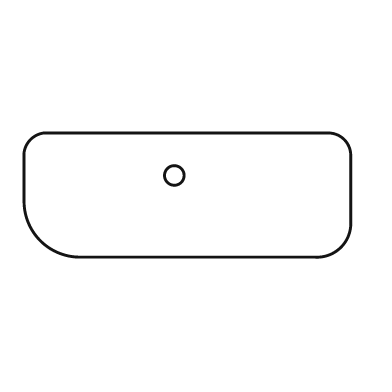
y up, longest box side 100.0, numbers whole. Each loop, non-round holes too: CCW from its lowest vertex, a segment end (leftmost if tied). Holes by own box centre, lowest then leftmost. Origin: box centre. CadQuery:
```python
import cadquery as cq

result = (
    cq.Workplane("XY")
    .moveTo(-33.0, -19.0)
    .lineTo(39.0, -19.0)
    .threePointArc((47.0, -16.0), (50.0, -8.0))
    .lineTo(50.0, 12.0)
    .threePointArc((48.0, 17.0), (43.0, 19.0))
    .lineTo(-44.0, 19.0)
    .threePointArc((-48.0, 17.0), (-50.0, 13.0))
    .lineTo(-50.0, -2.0)
    .threePointArc((-45.0, -14.0), (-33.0, -19.0))
    .close()
    .moveTo(-4.0, 6.0)
    .circle(3.0)
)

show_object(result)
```